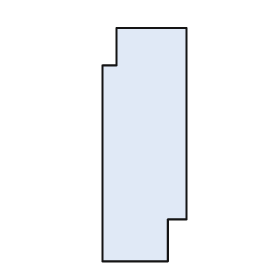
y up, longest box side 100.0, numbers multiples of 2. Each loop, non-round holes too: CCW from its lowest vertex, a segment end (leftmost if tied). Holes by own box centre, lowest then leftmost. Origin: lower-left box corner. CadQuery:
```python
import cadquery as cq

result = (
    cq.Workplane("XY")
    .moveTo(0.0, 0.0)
    .lineTo(28.0, 0.0)
    .lineTo(28.0, 18.0)
    .lineTo(36.0, 18.0)
    .lineTo(36.0, 100.0)
    .lineTo(6.0, 100.0)
    .lineTo(6.0, 84.0)
    .lineTo(0.0, 84.0)
    .close()
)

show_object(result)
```